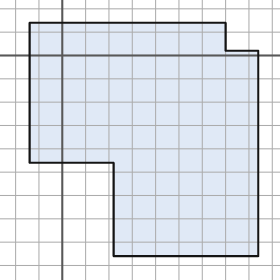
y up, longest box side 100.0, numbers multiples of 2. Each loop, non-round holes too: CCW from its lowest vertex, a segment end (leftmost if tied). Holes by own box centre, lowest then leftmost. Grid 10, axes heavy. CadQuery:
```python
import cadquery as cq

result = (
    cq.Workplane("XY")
    .moveTo(22.0, -86.0)
    .lineTo(84.0, -86.0)
    .lineTo(84.0, 2.0)
    .lineTo(70.0, 2.0)
    .lineTo(70.0, 14.0)
    .lineTo(-14.0, 14.0)
    .lineTo(-14.0, -46.0)
    .lineTo(22.0, -46.0)
    .close()
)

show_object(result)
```